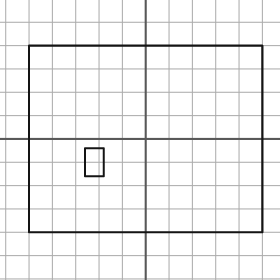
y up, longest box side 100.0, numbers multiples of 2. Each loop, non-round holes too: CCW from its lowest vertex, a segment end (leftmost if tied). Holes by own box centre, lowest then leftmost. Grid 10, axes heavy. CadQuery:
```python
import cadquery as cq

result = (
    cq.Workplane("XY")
    .moveTo(-50.0, -40.0)
    .lineTo(50.0, -40.0)
    .lineTo(50.0, 40.0)
    .lineTo(-50.0, 40.0)
    .close()
    .moveTo(-26.0, -16.0)
    .lineTo(-18.0, -16.0)
    .lineTo(-18.0, -4.0)
    .lineTo(-26.0, -4.0)
    .close()
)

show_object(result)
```